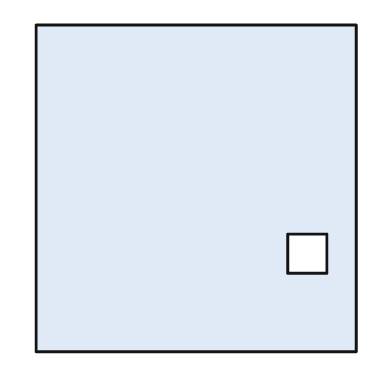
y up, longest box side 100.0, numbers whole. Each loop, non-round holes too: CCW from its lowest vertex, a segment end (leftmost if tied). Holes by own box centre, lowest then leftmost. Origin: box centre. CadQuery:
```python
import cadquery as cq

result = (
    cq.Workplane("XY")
    .moveTo(-49.0, -50.0)
    .lineTo(49.0, -50.0)
    .lineTo(49.0, 50.0)
    .lineTo(-49.0, 50.0)
    .close()
    .moveTo(28.0, -26.0)
    .lineTo(40.0, -26.0)
    .lineTo(40.0, -14.0)
    .lineTo(28.0, -14.0)
    .close()
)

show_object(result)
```